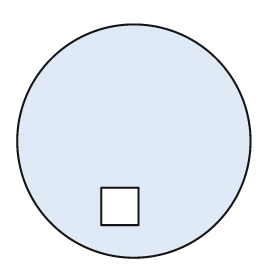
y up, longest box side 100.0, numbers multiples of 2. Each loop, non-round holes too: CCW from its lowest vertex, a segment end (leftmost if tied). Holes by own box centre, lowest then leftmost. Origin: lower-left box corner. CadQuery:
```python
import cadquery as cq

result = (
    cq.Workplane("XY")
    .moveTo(50.0, 50.0)
    .circle(50.0)
    .moveTo(36.0, 14.0)
    .lineTo(52.0, 14.0)
    .lineTo(52.0, 30.0)
    .lineTo(36.0, 30.0)
    .close()
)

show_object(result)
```